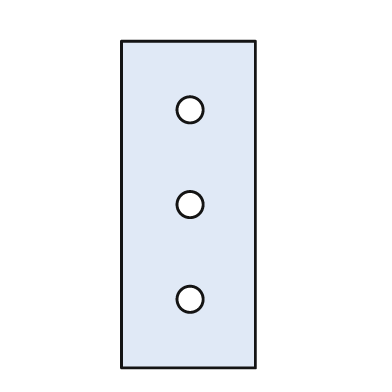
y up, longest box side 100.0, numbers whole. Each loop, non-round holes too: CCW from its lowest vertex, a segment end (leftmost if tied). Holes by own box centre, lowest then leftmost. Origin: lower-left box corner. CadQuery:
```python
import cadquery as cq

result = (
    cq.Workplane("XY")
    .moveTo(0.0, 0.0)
    .lineTo(41.0, 0.0)
    .lineTo(41.0, 100.0)
    .lineTo(0.0, 100.0)
    .close()
    .moveTo(21.0, 21.0)
    .circle(4.0)
    .moveTo(21.0, 50.0)
    .circle(4.0)
    .moveTo(21.0, 79.0)
    .circle(4.0)
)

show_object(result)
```